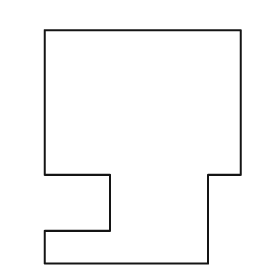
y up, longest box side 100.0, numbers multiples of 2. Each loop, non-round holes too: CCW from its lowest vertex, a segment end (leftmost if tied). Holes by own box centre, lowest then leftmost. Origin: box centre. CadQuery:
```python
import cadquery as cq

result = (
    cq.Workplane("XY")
    .moveTo(-42.0, -50.0)
    .lineTo(28.0, -50.0)
    .lineTo(28.0, -12.0)
    .lineTo(42.0, -12.0)
    .lineTo(42.0, 50.0)
    .lineTo(-42.0, 50.0)
    .lineTo(-42.0, -12.0)
    .lineTo(-14.0, -12.0)
    .lineTo(-14.0, -36.0)
    .lineTo(-42.0, -36.0)
    .close()
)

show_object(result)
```